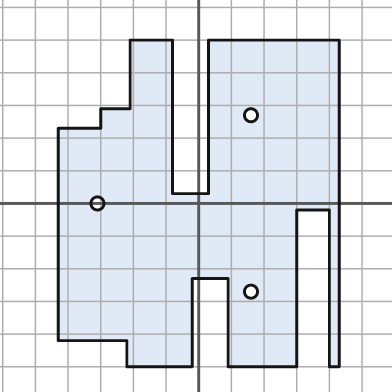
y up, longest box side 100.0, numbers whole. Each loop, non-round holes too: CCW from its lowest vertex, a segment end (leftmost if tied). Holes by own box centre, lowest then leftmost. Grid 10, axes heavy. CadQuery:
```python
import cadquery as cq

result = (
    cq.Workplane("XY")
    .moveTo(-22.0, -50.0)
    .lineTo(-2.0, -50.0)
    .lineTo(-2.0, -23.0)
    .lineTo(9.0, -23.0)
    .lineTo(9.0, -50.0)
    .lineTo(30.0, -50.0)
    .lineTo(30.0, -2.0)
    .lineTo(40.0, -2.0)
    .lineTo(40.0, -50.0)
    .lineTo(43.0, -50.0)
    .lineTo(43.0, 50.0)
    .lineTo(3.0, 50.0)
    .lineTo(3.0, 3.0)
    .lineTo(-8.0, 3.0)
    .lineTo(-8.0, 50.0)
    .lineTo(-21.0, 50.0)
    .lineTo(-21.0, 29.0)
    .lineTo(-30.0, 29.0)
    .lineTo(-30.0, 23.0)
    .lineTo(-43.0, 23.0)
    .lineTo(-43.0, -42.0)
    .lineTo(-22.0, -42.0)
    .close()
    .moveTo(16.0, -27.0)
    .circle(2.0)
    .moveTo(-31.0, 0.0)
    .circle(2.0)
    .moveTo(16.0, 27.0)
    .circle(2.0)
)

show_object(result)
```